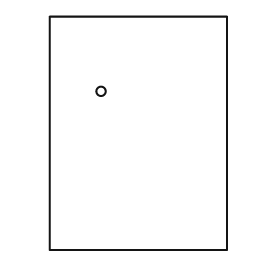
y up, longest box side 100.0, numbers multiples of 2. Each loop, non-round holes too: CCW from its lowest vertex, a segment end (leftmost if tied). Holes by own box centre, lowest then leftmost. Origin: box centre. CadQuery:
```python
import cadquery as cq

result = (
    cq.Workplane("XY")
    .moveTo(-38.0, -50.0)
    .lineTo(38.0, -50.0)
    .lineTo(38.0, 50.0)
    .lineTo(-38.0, 50.0)
    .close()
    .moveTo(-16.0, 18.0)
    .circle(2.0)
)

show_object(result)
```